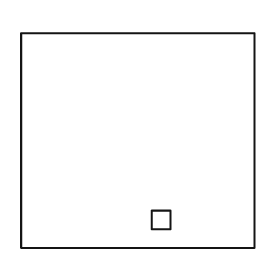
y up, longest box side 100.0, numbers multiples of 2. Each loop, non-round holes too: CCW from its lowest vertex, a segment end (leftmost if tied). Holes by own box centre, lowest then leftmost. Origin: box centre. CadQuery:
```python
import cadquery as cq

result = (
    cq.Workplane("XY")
    .moveTo(-50.0, -46.0)
    .lineTo(50.0, -46.0)
    .lineTo(50.0, 46.0)
    .lineTo(-50.0, 46.0)
    .close()
    .moveTo(6.0, -38.0)
    .lineTo(14.0, -38.0)
    .lineTo(14.0, -30.0)
    .lineTo(6.0, -30.0)
    .close()
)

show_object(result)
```